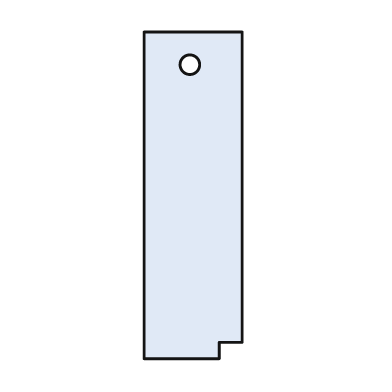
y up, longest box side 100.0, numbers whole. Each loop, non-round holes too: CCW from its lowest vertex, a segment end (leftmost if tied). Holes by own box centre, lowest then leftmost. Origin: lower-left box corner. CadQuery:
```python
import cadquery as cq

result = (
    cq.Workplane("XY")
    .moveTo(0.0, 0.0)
    .lineTo(23.0, 0.0)
    .lineTo(23.0, 5.0)
    .lineTo(30.0, 5.0)
    .lineTo(30.0, 100.0)
    .lineTo(0.0, 100.0)
    .close()
    .moveTo(14.0, 90.0)
    .circle(3.0)
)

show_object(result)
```